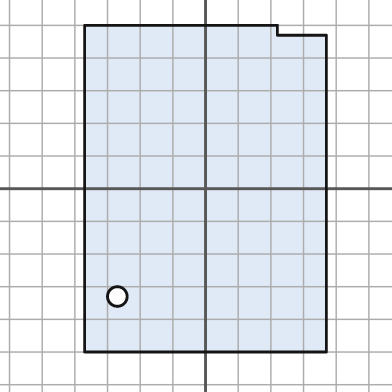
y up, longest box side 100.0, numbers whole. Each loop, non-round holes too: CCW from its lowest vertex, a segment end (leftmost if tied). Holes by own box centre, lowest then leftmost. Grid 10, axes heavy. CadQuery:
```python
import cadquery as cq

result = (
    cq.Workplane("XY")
    .moveTo(-37.0, -50.0)
    .lineTo(37.0, -50.0)
    .lineTo(37.0, 47.0)
    .lineTo(22.0, 47.0)
    .lineTo(22.0, 50.0)
    .lineTo(-37.0, 50.0)
    .close()
    .moveTo(-27.0, -33.0)
    .circle(3.0)
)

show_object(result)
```